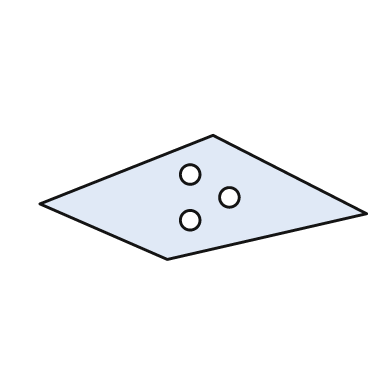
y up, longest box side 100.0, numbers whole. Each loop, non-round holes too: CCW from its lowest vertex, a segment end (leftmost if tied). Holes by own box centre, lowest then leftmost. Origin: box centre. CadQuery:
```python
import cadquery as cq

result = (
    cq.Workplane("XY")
    .moveTo(-11.0, -19.0)
    .lineTo(50.0, -5.0)
    .lineTo(3.0, 19.0)
    .lineTo(-50.0, -2.0)
    .close()
    .moveTo(-4.0, -7.0)
    .circle(3.0)
    .moveTo(8.0, 0.0)
    .circle(3.0)
    .moveTo(-4.0, 7.0)
    .circle(3.0)
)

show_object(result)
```